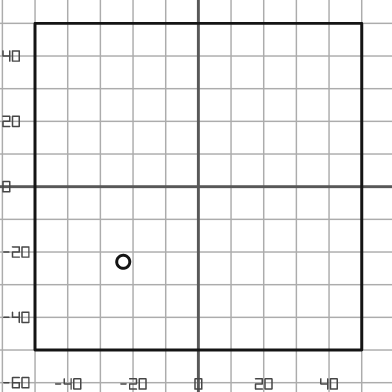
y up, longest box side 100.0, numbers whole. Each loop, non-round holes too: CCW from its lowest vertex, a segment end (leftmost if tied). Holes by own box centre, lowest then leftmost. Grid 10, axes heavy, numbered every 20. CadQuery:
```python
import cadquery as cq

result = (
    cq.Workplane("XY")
    .moveTo(-50.0, -50.0)
    .lineTo(50.0, -50.0)
    .lineTo(50.0, 50.0)
    .lineTo(-50.0, 50.0)
    .close()
    .moveTo(-23.0, -23.0)
    .circle(2.0)
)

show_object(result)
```